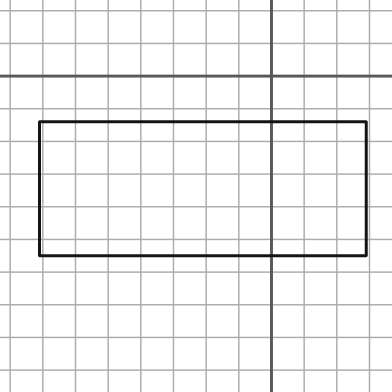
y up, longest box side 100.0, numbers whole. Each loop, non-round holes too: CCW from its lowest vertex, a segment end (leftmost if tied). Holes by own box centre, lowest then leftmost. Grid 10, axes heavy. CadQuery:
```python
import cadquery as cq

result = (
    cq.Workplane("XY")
    .moveTo(-71.0, -55.0)
    .lineTo(29.0, -55.0)
    .lineTo(29.0, -14.0)
    .lineTo(-71.0, -14.0)
    .close()
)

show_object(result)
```